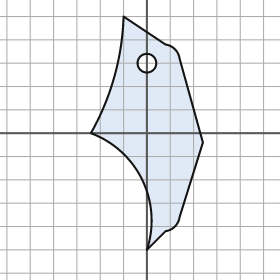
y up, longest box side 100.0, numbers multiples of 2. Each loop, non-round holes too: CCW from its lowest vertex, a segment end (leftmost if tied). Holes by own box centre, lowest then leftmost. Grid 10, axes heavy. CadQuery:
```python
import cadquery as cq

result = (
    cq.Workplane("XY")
    .moveTo(0.0, -50.0)
    .lineTo(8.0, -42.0)
    .threePointArc((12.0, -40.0), (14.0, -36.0))
    .lineTo(24.0, -4.0)
    .lineTo(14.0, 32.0)
    .threePointArc((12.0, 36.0), (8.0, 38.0))
    .lineTo(-10.0, 50.0)
    .threePointArc((-14.0, 24.0), (-24.0, 0.0))
    .threePointArc((-2.0, -20.0), (0.0, -50.0))
    .close()
    .moveTo(0.0, 30.0)
    .circle(4.0)
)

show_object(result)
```